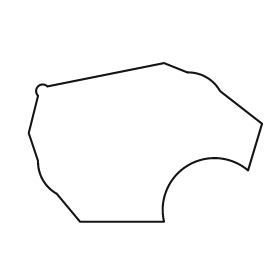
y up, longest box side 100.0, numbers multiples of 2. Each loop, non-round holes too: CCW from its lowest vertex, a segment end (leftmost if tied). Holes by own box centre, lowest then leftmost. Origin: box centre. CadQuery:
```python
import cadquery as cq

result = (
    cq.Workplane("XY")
    .moveTo(-28.0, -34.0)
    .lineTo(8.0, -34.0)
    .threePointArc((18.0, -10.0), (44.0, -12.0))
    .lineTo(50.0, 8.0)
    .lineTo(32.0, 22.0)
    .threePointArc((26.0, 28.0), (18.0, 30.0))
    .lineTo(8.0, 34.0)
    .lineTo(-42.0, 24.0)
    .threePointArc((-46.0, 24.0), (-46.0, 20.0))
    .lineTo(-50.0, 4.0)
    .lineTo(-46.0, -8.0)
    .threePointArc((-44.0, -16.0), (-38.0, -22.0))
    .close()
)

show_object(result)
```